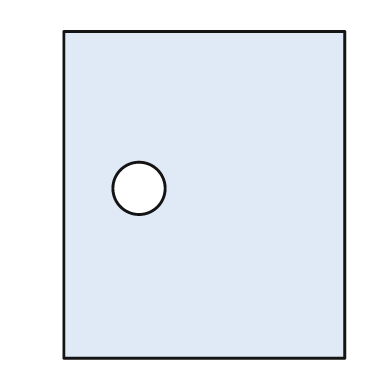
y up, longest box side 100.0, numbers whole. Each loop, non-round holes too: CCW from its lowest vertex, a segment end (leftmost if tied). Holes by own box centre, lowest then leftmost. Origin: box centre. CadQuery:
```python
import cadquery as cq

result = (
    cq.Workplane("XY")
    .moveTo(-43.0, -50.0)
    .lineTo(43.0, -50.0)
    .lineTo(43.0, 50.0)
    .lineTo(-43.0, 50.0)
    .close()
    .moveTo(-20.0, 2.0)
    .circle(8.0)
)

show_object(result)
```